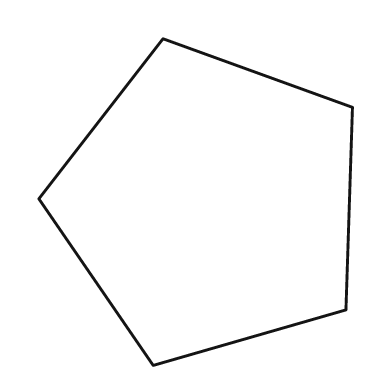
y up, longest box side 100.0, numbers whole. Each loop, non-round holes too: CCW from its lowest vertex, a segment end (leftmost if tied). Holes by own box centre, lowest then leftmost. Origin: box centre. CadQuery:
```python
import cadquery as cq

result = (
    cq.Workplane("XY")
    .moveTo(-13.0, -50.0)
    .lineTo(46.0, -33.0)
    .lineTo(48.0, 29.0)
    .lineTo(-10.0, 50.0)
    .lineTo(-48.0, 1.0)
    .close()
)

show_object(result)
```